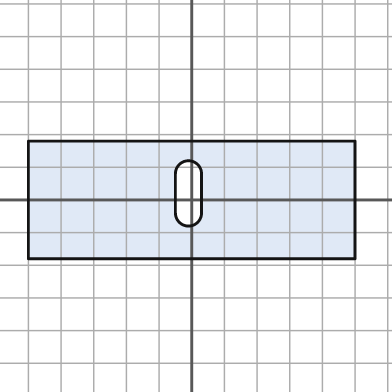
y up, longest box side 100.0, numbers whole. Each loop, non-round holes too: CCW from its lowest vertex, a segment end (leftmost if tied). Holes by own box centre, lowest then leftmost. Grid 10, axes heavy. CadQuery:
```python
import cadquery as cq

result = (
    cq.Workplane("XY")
    .moveTo(-50.0, -18.0)
    .lineTo(50.0, -18.0)
    .lineTo(50.0, 18.0)
    .lineTo(-50.0, 18.0)
    .close()
    .moveTo(-5.0, -4.0)
    .threePointArc((-1.0, -8.0), (3.0, -4.0))
    .lineTo(3.0, 8.0)
    .threePointArc((-1.0, 12.0), (-5.0, 8.0))
    .close()
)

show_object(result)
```